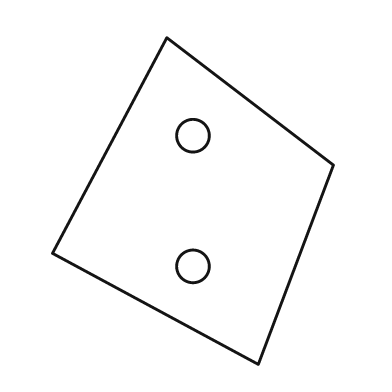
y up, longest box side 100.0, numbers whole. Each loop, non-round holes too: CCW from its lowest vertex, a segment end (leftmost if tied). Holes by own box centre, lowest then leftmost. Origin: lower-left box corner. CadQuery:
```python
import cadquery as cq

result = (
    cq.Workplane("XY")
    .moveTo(63.0, 0.0)
    .lineTo(86.0, 61.0)
    .lineTo(35.0, 100.0)
    .lineTo(0.0, 34.0)
    .close()
    .moveTo(43.0, 30.0)
    .circle(5.0)
    .moveTo(43.0, 70.0)
    .circle(5.0)
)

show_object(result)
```